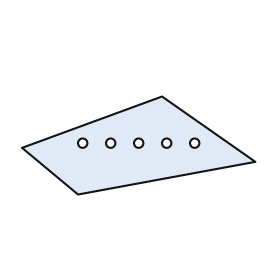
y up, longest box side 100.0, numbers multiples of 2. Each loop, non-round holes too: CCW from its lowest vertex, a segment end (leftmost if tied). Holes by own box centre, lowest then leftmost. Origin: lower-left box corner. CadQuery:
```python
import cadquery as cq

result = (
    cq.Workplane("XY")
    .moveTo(24.0, 0.0)
    .lineTo(100.0, 14.0)
    .lineTo(60.0, 42.0)
    .lineTo(0.0, 20.0)
    .close()
    .moveTo(26.0, 22.0)
    .circle(2.0)
    .moveTo(38.0, 22.0)
    .circle(2.0)
    .moveTo(50.0, 22.0)
    .circle(2.0)
    .moveTo(62.0, 22.0)
    .circle(2.0)
    .moveTo(74.0, 22.0)
    .circle(2.0)
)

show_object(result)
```